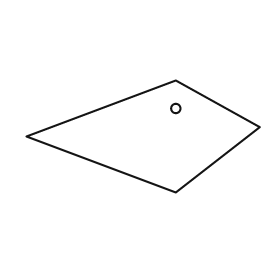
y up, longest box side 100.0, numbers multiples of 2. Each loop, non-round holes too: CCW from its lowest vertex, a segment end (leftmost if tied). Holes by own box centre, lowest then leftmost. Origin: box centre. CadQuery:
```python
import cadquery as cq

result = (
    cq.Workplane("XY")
    .moveTo(14.0, -24.0)
    .lineTo(50.0, 4.0)
    .lineTo(14.0, 24.0)
    .lineTo(-50.0, 0.0)
    .close()
    .moveTo(14.0, 12.0)
    .circle(2.0)
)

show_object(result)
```